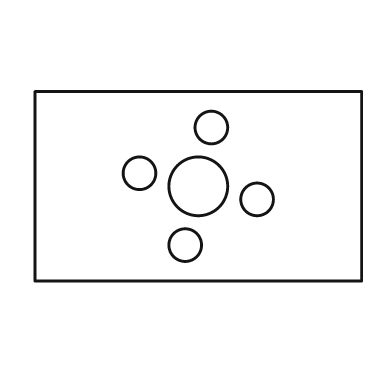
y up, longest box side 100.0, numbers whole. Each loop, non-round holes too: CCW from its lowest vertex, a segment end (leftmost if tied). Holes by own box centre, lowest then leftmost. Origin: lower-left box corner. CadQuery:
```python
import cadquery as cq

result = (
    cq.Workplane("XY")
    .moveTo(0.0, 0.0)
    .lineTo(100.0, 0.0)
    .lineTo(100.0, 58.0)
    .lineTo(0.0, 58.0)
    .close()
    .moveTo(46.0, 11.0)
    .circle(5.0)
    .moveTo(68.0, 25.0)
    .circle(5.0)
    .moveTo(50.0, 29.0)
    .circle(9.0)
    .moveTo(32.0, 33.0)
    .circle(5.0)
    .moveTo(54.0, 47.0)
    .circle(5.0)
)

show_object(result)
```